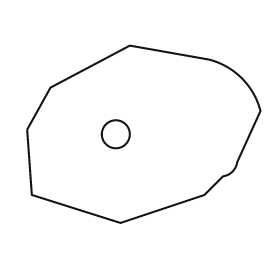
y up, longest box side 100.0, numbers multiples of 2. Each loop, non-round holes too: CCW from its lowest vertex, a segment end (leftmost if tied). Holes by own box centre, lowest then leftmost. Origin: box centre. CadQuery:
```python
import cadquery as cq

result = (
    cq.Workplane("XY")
    .moveTo(-10.0, -38.0)
    .lineTo(26.0, -26.0)
    .lineTo(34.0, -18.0)
    .threePointArc((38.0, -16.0), (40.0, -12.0))
    .lineTo(50.0, 10.0)
    .threePointArc((42.0, 24.0), (28.0, 32.0))
    .lineTo(-6.0, 38.0)
    .lineTo(-40.0, 20.0)
    .lineTo(-50.0, 2.0)
    .lineTo(-48.0, -26.0)
    .close()
    .moveTo(-12.0, 0.0)
    .circle(6.0)
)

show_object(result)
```